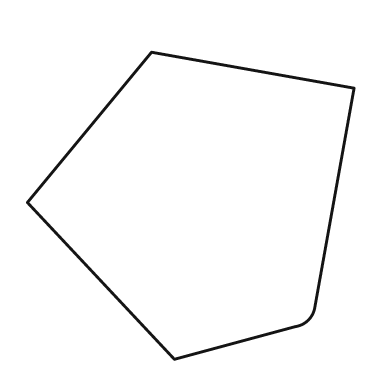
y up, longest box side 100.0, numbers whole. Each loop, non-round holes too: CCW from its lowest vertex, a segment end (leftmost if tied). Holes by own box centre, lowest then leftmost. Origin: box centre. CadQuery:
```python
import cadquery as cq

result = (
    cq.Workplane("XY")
    .moveTo(-5.0, -47.0)
    .lineTo(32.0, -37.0)
    .threePointArc((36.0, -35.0), (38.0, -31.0))
    .lineTo(50.0, 36.0)
    .lineTo(-12.0, 47.0)
    .lineTo(-50.0, 1.0)
    .close()
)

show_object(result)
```